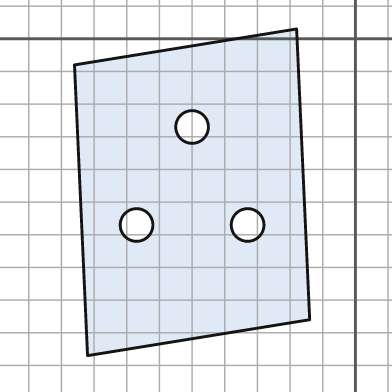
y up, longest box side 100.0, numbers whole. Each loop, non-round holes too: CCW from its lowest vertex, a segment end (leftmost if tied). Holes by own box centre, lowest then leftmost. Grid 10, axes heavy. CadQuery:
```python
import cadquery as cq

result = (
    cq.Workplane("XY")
    .moveTo(-82.0, -97.0)
    .lineTo(-14.0, -86.0)
    .lineTo(-18.0, 3.0)
    .lineTo(-86.0, -8.0)
    .close()
    .moveTo(-67.0, -57.0)
    .circle(5.0)
    .moveTo(-33.0, -57.0)
    .circle(5.0)
    .moveTo(-50.0, -27.0)
    .circle(5.0)
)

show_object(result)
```